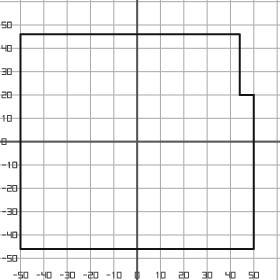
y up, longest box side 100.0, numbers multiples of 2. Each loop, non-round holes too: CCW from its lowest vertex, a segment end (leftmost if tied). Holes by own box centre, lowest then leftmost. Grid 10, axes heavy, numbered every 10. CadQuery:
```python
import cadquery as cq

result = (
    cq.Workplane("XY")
    .moveTo(-50.0, -46.0)
    .lineTo(50.0, -46.0)
    .lineTo(50.0, 20.0)
    .lineTo(44.0, 20.0)
    .lineTo(44.0, 46.0)
    .lineTo(-50.0, 46.0)
    .close()
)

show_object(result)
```